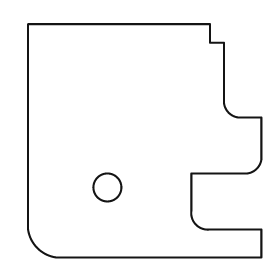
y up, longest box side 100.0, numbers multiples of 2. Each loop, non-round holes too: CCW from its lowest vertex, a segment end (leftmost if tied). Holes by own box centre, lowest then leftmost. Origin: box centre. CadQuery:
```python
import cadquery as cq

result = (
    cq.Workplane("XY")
    .moveTo(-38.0, -50.0)
    .lineTo(50.0, -50.0)
    .lineTo(50.0, -38.0)
    .lineTo(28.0, -38.0)
    .threePointArc((22.0, -36.0), (20.0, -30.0))
    .lineTo(20.0, -14.0)
    .lineTo(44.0, -14.0)
    .threePointArc((48.0, -12.0), (50.0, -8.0))
    .lineTo(50.0, 10.0)
    .lineTo(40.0, 10.0)
    .threePointArc((36.0, 12.0), (34.0, 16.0))
    .lineTo(34.0, 42.0)
    .lineTo(28.0, 42.0)
    .lineTo(28.0, 50.0)
    .lineTo(-50.0, 50.0)
    .lineTo(-50.0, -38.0)
    .threePointArc((-46.0, -46.0), (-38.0, -50.0))
    .close()
    .moveTo(-16.0, -20.0)
    .circle(6.0)
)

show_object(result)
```